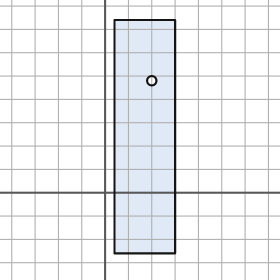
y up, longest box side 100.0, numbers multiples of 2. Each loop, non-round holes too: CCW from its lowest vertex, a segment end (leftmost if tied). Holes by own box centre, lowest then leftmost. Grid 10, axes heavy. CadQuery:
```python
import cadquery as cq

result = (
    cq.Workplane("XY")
    .moveTo(4.0, -26.0)
    .lineTo(30.0, -26.0)
    .lineTo(30.0, 74.0)
    .lineTo(4.0, 74.0)
    .close()
    .moveTo(20.0, 48.0)
    .circle(2.0)
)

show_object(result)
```